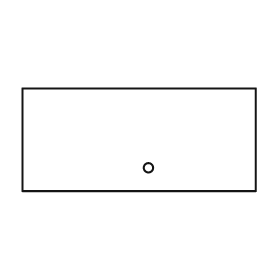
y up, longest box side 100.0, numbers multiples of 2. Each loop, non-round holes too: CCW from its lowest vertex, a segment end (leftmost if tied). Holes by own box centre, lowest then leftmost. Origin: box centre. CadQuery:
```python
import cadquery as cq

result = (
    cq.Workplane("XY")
    .moveTo(-50.0, -22.0)
    .lineTo(50.0, -22.0)
    .lineTo(50.0, 22.0)
    .lineTo(-50.0, 22.0)
    .close()
    .moveTo(4.0, -12.0)
    .circle(2.0)
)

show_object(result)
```